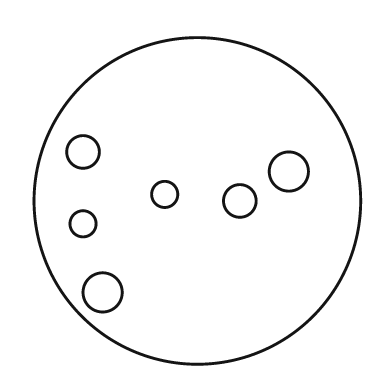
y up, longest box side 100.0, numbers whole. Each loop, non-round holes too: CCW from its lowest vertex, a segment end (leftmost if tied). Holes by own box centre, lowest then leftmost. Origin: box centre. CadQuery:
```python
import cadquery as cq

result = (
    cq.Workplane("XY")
    .moveTo(0.0, 0.0)
    .circle(50.0)
    .moveTo(-29.0, -28.0)
    .circle(6.0)
    .moveTo(-35.0, -7.0)
    .circle(4.0)
    .moveTo(13.0, 0.0)
    .circle(5.0)
    .moveTo(-10.0, 2.0)
    .circle(4.0)
    .moveTo(28.0, 9.0)
    .circle(6.0)
    .moveTo(-35.0, 15.0)
    .circle(5.0)
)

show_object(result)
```